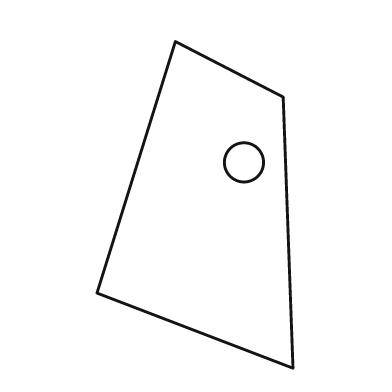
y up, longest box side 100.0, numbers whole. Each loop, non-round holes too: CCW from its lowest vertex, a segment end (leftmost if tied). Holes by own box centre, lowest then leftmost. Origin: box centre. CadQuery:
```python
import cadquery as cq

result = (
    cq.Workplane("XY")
    .moveTo(30.0, -50.0)
    .lineTo(27.0, 33.0)
    .lineTo(-6.0, 50.0)
    .lineTo(-30.0, -27.0)
    .close()
    .moveTo(15.0, 13.0)
    .circle(6.0)
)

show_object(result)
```